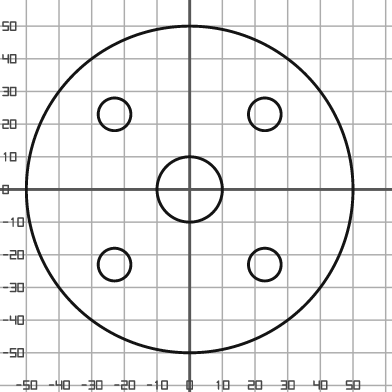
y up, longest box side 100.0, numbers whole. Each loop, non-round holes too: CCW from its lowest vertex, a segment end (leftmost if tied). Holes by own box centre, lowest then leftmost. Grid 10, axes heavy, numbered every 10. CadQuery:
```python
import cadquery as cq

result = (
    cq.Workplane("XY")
    .moveTo(0.0, 0.0)
    .circle(50.0)
    .moveTo(-23.0, -23.0)
    .circle(5.0)
    .moveTo(23.0, -23.0)
    .circle(5.0)
    .moveTo(0.0, 0.0)
    .circle(10.0)
    .moveTo(-23.0, 23.0)
    .circle(5.0)
    .moveTo(23.0, 23.0)
    .circle(5.0)
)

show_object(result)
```